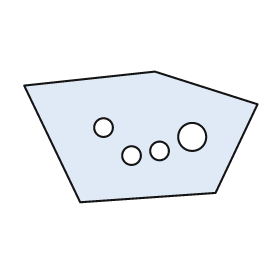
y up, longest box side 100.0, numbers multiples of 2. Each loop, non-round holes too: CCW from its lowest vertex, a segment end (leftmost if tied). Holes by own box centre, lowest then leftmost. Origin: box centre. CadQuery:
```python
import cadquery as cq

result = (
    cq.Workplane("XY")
    .moveTo(-26.0, -28.0)
    .lineTo(32.0, -24.0)
    .lineTo(50.0, 14.0)
    .lineTo(6.0, 28.0)
    .lineTo(-50.0, 22.0)
    .close()
    .moveTo(-4.0, -8.0)
    .circle(4.0)
    .moveTo(8.0, -6.0)
    .circle(4.0)
    .moveTo(22.0, 0.0)
    .circle(6.0)
    .moveTo(-16.0, 4.0)
    .circle(4.0)
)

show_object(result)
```